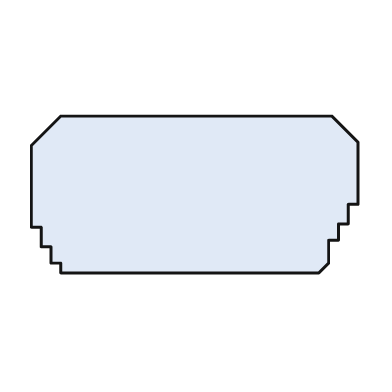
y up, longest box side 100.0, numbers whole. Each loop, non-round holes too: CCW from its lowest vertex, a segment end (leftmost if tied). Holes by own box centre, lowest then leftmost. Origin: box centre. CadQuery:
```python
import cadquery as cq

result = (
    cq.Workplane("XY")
    .moveTo(-41.0, -24.0)
    .lineTo(38.0, -24.0)
    .lineTo(41.0, -21.0)
    .lineTo(41.0, -14.0)
    .lineTo(44.0, -14.0)
    .lineTo(44.0, -9.0)
    .lineTo(47.0, -9.0)
    .lineTo(47.0, -3.0)
    .lineTo(50.0, -3.0)
    .lineTo(50.0, 16.0)
    .lineTo(42.0, 24.0)
    .lineTo(-41.0, 24.0)
    .lineTo(-50.0, 15.0)
    .lineTo(-50.0, -10.0)
    .lineTo(-47.0, -10.0)
    .lineTo(-47.0, -16.0)
    .lineTo(-44.0, -16.0)
    .lineTo(-44.0, -21.0)
    .lineTo(-41.0, -21.0)
    .close()
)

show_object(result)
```